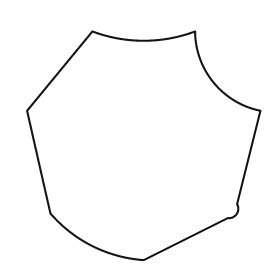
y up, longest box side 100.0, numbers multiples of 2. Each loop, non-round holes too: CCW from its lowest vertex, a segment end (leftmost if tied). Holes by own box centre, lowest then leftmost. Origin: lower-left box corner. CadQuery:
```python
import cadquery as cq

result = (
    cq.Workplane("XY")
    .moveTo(50.0, 0.0)
    .lineTo(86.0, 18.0)
    .threePointArc((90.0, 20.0), (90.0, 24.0))
    .lineTo(100.0, 64.0)
    .threePointArc((80.0, 76.0), (72.0, 98.0))
    .threePointArc((50.0, 94.0), (28.0, 98.0))
    .lineTo(0.0, 64.0)
    .lineTo(10.0, 20.0)
    .threePointArc((28.0, 6.0), (50.0, 0.0))
    .close()
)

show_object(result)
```